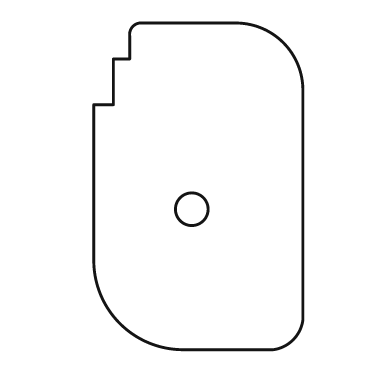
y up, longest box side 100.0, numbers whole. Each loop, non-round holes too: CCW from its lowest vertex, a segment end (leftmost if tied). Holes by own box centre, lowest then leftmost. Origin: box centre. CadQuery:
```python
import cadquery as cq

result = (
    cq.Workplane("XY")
    .moveTo(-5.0, -50.0)
    .lineTo(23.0, -50.0)
    .threePointArc((29.0, -47.0), (32.0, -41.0))
    .lineTo(32.0, 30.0)
    .threePointArc((26.0, 44.0), (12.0, 50.0))
    .lineTo(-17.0, 50.0)
    .threePointArc((-20.0, 49.0), (-21.0, 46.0))
    .lineTo(-21.0, 39.0)
    .lineTo(-26.0, 39.0)
    .lineTo(-26.0, 25.0)
    .lineTo(-32.0, 25.0)
    .lineTo(-32.0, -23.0)
    .threePointArc((-24.0, -42.0), (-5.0, -50.0))
    .close()
    .moveTo(-2.0, -7.0)
    .circle(5.0)
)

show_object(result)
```